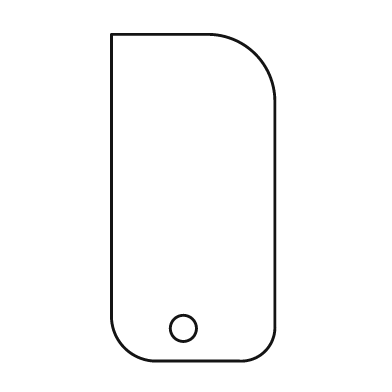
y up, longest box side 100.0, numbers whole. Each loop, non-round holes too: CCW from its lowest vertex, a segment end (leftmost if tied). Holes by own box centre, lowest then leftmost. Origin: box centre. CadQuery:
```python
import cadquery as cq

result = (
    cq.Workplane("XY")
    .moveTo(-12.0, -50.0)
    .lineTo(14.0, -50.0)
    .threePointArc((22.0, -47.0), (25.0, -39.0))
    .lineTo(25.0, 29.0)
    .threePointArc((19.0, 44.0), (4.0, 50.0))
    .lineTo(-25.0, 50.0)
    .lineTo(-25.0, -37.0)
    .threePointArc((-21.0, -46.0), (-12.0, -50.0))
    .close()
    .moveTo(-3.0, -40.0)
    .circle(4.0)
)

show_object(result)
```